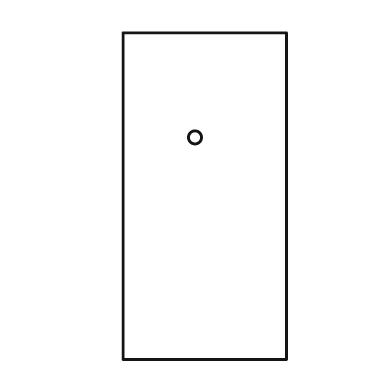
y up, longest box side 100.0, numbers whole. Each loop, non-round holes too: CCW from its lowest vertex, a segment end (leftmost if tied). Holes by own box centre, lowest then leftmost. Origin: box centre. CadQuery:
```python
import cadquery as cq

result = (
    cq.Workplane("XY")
    .moveTo(-25.0, -50.0)
    .lineTo(25.0, -50.0)
    .lineTo(25.0, 50.0)
    .lineTo(-25.0, 50.0)
    .close()
    .moveTo(-3.0, 18.0)
    .circle(2.0)
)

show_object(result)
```